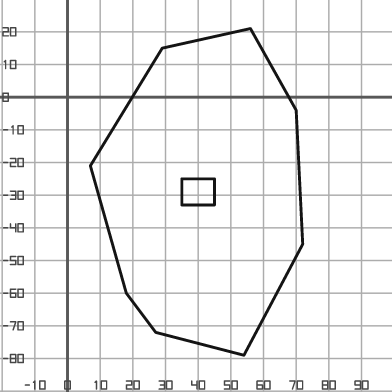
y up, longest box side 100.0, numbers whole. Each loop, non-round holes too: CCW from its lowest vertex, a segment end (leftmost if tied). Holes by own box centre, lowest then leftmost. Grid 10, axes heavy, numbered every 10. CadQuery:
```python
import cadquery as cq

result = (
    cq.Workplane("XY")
    .moveTo(54.0, -79.0)
    .lineTo(72.0, -45.0)
    .lineTo(70.0, -4.0)
    .lineTo(56.0, 21.0)
    .lineTo(29.0, 15.0)
    .lineTo(7.0, -21.0)
    .lineTo(18.0, -60.0)
    .lineTo(27.0, -72.0)
    .close()
    .moveTo(35.0, -33.0)
    .lineTo(45.0, -33.0)
    .lineTo(45.0, -25.0)
    .lineTo(35.0, -25.0)
    .close()
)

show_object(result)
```